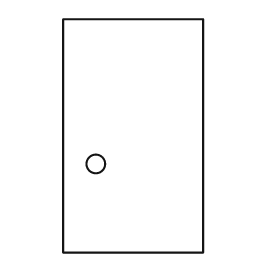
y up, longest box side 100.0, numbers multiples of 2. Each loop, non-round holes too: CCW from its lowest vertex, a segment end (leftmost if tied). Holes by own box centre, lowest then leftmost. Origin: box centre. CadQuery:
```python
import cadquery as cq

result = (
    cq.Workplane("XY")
    .moveTo(-30.0, -50.0)
    .lineTo(30.0, -50.0)
    .lineTo(30.0, 50.0)
    .lineTo(-30.0, 50.0)
    .close()
    .moveTo(-16.0, -12.0)
    .circle(4.0)
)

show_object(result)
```